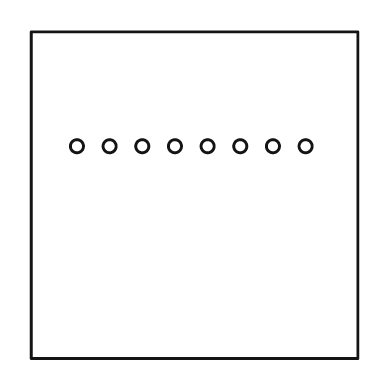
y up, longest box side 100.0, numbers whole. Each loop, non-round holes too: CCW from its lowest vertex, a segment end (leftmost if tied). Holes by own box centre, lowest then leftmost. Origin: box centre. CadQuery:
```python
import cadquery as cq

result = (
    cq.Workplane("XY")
    .moveTo(-50.0, -50.0)
    .lineTo(50.0, -50.0)
    .lineTo(50.0, 50.0)
    .lineTo(-50.0, 50.0)
    .close()
    .moveTo(-36.0, 15.0)
    .circle(2.0)
    .moveTo(-26.0, 15.0)
    .circle(2.0)
    .moveTo(-16.0, 15.0)
    .circle(2.0)
    .moveTo(-6.0, 15.0)
    .circle(2.0)
    .moveTo(4.0, 15.0)
    .circle(2.0)
    .moveTo(14.0, 15.0)
    .circle(2.0)
    .moveTo(24.0, 15.0)
    .circle(2.0)
    .moveTo(34.0, 15.0)
    .circle(2.0)
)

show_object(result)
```